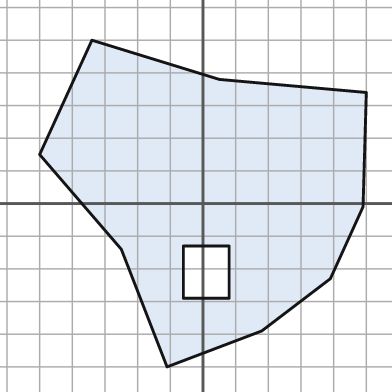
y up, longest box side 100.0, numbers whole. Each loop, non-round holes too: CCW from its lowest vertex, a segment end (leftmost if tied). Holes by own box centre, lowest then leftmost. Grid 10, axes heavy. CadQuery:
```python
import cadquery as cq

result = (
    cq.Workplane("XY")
    .moveTo(-11.0, -50.0)
    .lineTo(18.0, -39.0)
    .lineTo(39.0, -23.0)
    .lineTo(49.0, -1.0)
    .lineTo(50.0, 34.0)
    .lineTo(5.0, 38.0)
    .lineTo(-34.0, 50.0)
    .lineTo(-50.0, 15.0)
    .lineTo(-25.0, -14.0)
    .close()
    .moveTo(-6.0, -29.0)
    .lineTo(8.0, -29.0)
    .lineTo(8.0, -13.0)
    .lineTo(-6.0, -13.0)
    .close()
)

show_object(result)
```